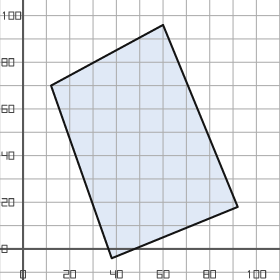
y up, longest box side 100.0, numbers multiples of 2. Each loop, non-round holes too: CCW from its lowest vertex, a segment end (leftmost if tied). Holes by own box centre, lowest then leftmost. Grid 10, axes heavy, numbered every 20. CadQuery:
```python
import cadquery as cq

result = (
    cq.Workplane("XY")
    .moveTo(38.0, -4.0)
    .lineTo(92.0, 18.0)
    .lineTo(60.0, 96.0)
    .lineTo(12.0, 70.0)
    .close()
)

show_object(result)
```